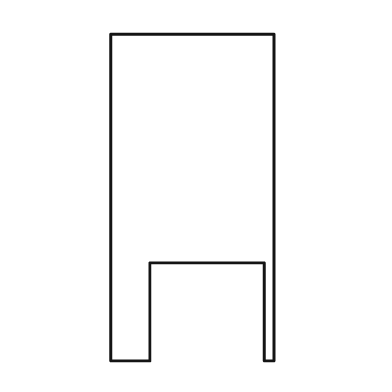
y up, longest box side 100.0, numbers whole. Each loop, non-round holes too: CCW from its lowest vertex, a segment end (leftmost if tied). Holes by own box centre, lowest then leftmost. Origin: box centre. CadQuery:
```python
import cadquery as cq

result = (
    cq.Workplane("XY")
    .moveTo(-25.0, -50.0)
    .lineTo(-13.0, -50.0)
    .lineTo(-13.0, -20.0)
    .lineTo(22.0, -20.0)
    .lineTo(22.0, -50.0)
    .lineTo(25.0, -50.0)
    .lineTo(25.0, 50.0)
    .lineTo(-25.0, 50.0)
    .close()
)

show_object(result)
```